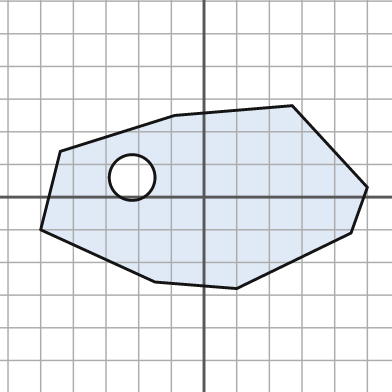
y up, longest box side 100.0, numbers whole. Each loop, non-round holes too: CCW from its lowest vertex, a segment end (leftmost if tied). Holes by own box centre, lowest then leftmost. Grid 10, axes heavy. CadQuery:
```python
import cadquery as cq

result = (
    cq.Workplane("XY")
    .moveTo(10.0, -28.0)
    .lineTo(45.0, -11.0)
    .lineTo(50.0, 3.0)
    .lineTo(27.0, 28.0)
    .lineTo(-9.0, 25.0)
    .lineTo(-44.0, 14.0)
    .lineTo(-50.0, -10.0)
    .lineTo(-15.0, -26.0)
    .close()
    .moveTo(-22.0, 6.0)
    .circle(7.0)
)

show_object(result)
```